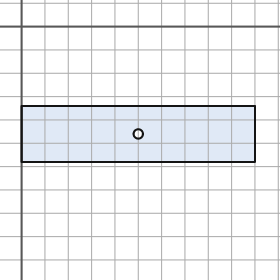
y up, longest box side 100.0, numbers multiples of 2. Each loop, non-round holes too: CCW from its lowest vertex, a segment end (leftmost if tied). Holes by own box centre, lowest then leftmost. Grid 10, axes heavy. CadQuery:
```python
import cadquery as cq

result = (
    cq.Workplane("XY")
    .moveTo(0.0, -58.0)
    .lineTo(100.0, -58.0)
    .lineTo(100.0, -34.0)
    .lineTo(0.0, -34.0)
    .close()
    .moveTo(50.0, -46.0)
    .circle(2.0)
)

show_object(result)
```